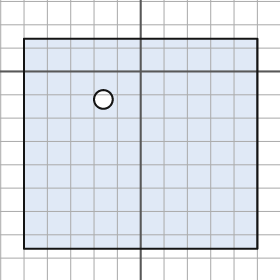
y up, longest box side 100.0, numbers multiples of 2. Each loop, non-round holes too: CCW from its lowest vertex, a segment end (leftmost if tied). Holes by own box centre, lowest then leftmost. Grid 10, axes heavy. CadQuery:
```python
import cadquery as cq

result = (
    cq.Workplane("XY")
    .moveTo(-50.0, -76.0)
    .lineTo(50.0, -76.0)
    .lineTo(50.0, 14.0)
    .lineTo(-50.0, 14.0)
    .close()
    .moveTo(-16.0, -12.0)
    .circle(4.0)
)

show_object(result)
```